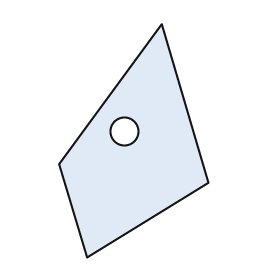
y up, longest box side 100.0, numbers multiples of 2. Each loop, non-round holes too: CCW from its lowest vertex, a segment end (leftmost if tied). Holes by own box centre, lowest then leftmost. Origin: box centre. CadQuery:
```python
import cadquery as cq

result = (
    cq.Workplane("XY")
    .moveTo(-20.0, -50.0)
    .lineTo(32.0, -18.0)
    .lineTo(12.0, 50.0)
    .lineTo(-32.0, -10.0)
    .close()
    .moveTo(-4.0, 4.0)
    .circle(6.0)
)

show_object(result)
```